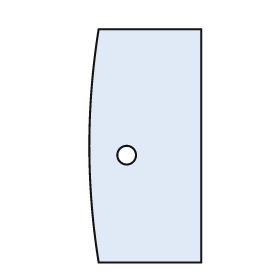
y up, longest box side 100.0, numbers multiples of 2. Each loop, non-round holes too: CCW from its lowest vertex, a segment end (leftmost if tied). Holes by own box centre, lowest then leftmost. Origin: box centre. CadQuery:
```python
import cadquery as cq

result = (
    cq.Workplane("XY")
    .moveTo(-20.0, -50.0)
    .lineTo(24.0, -50.0)
    .lineTo(24.0, 50.0)
    .lineTo(-20.0, 50.0)
    .threePointArc((-24.0, 0.0), (-20.0, -50.0))
    .close()
    .moveTo(-8.0, -4.0)
    .circle(4.0)
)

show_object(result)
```